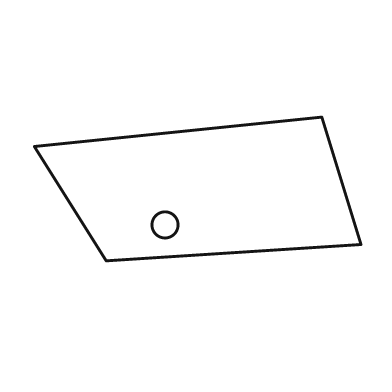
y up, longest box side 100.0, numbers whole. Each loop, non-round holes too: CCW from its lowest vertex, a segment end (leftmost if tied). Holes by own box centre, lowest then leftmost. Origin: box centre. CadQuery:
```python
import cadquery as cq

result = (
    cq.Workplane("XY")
    .moveTo(-28.0, -22.0)
    .lineTo(50.0, -17.0)
    .lineTo(38.0, 22.0)
    .lineTo(-50.0, 13.0)
    .close()
    .moveTo(-10.0, -11.0)
    .circle(4.0)
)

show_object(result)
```